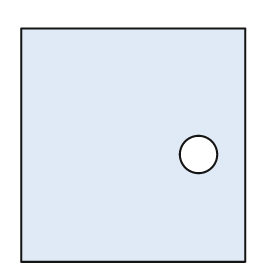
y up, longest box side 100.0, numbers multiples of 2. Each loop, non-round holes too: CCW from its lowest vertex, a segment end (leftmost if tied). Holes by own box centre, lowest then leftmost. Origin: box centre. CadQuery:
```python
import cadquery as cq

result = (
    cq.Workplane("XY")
    .moveTo(-48.0, -50.0)
    .lineTo(48.0, -50.0)
    .lineTo(48.0, 50.0)
    .lineTo(-48.0, 50.0)
    .close()
    .moveTo(28.0, -4.0)
    .circle(8.0)
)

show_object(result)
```